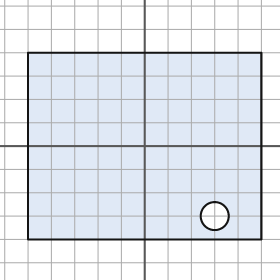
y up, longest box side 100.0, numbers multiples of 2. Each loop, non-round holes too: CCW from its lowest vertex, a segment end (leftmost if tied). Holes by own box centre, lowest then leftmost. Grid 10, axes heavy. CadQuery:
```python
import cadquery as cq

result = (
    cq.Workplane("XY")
    .moveTo(-50.0, -40.0)
    .lineTo(50.0, -40.0)
    .lineTo(50.0, 40.0)
    .lineTo(-50.0, 40.0)
    .close()
    .moveTo(30.0, -30.0)
    .circle(6.0)
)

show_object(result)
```